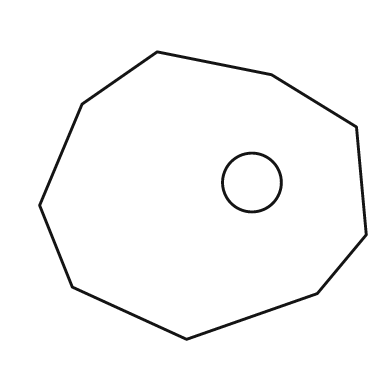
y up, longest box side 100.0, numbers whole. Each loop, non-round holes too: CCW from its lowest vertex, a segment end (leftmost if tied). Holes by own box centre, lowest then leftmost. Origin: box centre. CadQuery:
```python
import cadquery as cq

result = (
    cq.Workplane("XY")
    .moveTo(-5.0, -44.0)
    .lineTo(35.0, -30.0)
    .lineTo(50.0, -12.0)
    .lineTo(47.0, 21.0)
    .lineTo(21.0, 37.0)
    .lineTo(-14.0, 44.0)
    .lineTo(-37.0, 28.0)
    .lineTo(-50.0, -3.0)
    .lineTo(-40.0, -28.0)
    .close()
    .moveTo(15.0, 4.0)
    .circle(9.0)
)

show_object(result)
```